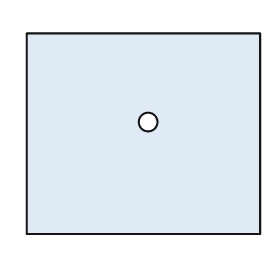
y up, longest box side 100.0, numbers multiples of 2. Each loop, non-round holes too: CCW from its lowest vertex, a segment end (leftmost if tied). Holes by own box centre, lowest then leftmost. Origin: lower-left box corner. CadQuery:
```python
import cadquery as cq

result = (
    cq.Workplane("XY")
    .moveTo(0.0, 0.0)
    .lineTo(100.0, 0.0)
    .lineTo(100.0, 86.0)
    .lineTo(0.0, 86.0)
    .close()
    .moveTo(52.0, 48.0)
    .circle(4.0)
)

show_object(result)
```